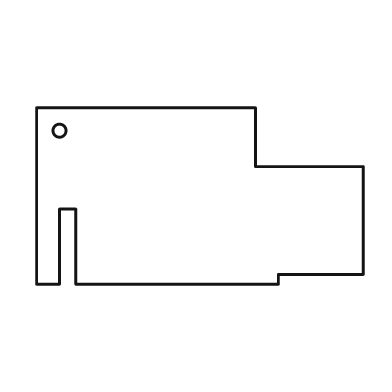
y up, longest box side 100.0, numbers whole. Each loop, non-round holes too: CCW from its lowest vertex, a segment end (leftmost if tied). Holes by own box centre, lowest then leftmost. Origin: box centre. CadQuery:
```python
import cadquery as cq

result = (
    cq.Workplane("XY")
    .moveTo(-50.0, -27.0)
    .lineTo(-43.0, -27.0)
    .lineTo(-43.0, -4.0)
    .lineTo(-38.0, -4.0)
    .lineTo(-38.0, -27.0)
    .lineTo(24.0, -27.0)
    .lineTo(24.0, -24.0)
    .lineTo(50.0, -24.0)
    .lineTo(50.0, 9.0)
    .lineTo(17.0, 9.0)
    .lineTo(17.0, 27.0)
    .lineTo(-50.0, 27.0)
    .close()
    .moveTo(-43.0, 20.0)
    .circle(2.0)
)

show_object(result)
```